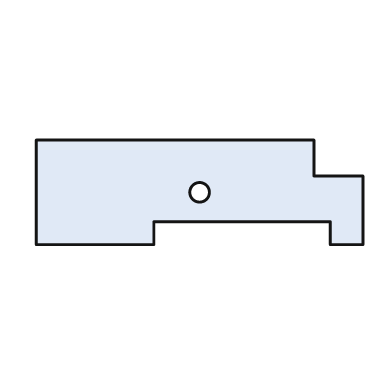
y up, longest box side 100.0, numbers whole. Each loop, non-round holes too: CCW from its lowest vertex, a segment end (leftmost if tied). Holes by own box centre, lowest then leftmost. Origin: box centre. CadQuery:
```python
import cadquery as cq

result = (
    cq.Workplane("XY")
    .moveTo(-50.0, -16.0)
    .lineTo(-14.0, -16.0)
    .lineTo(-14.0, -9.0)
    .lineTo(40.0, -9.0)
    .lineTo(40.0, -16.0)
    .lineTo(50.0, -16.0)
    .lineTo(50.0, 5.0)
    .lineTo(35.0, 5.0)
    .lineTo(35.0, 16.0)
    .lineTo(-50.0, 16.0)
    .close()
    .moveTo(0.0, 0.0)
    .circle(3.0)
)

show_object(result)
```